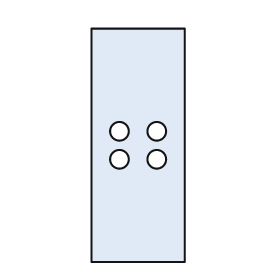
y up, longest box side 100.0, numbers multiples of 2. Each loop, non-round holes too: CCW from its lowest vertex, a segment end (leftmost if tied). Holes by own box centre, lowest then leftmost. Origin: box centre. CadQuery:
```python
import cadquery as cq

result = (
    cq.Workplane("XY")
    .moveTo(-20.0, -50.0)
    .lineTo(20.0, -50.0)
    .lineTo(20.0, 50.0)
    .lineTo(-20.0, 50.0)
    .close()
    .moveTo(-8.0, -6.0)
    .circle(4.0)
    .moveTo(8.0, -6.0)
    .circle(4.0)
    .moveTo(-8.0, 6.0)
    .circle(4.0)
    .moveTo(8.0, 6.0)
    .circle(4.0)
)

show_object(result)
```